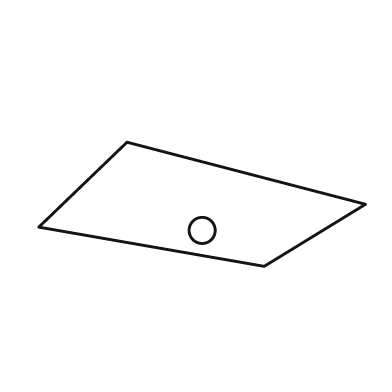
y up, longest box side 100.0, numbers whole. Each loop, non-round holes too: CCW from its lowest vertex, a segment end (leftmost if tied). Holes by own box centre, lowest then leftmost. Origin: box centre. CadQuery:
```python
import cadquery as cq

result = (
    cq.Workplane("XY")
    .moveTo(19.0, -19.0)
    .lineTo(50.0, 0.0)
    .lineTo(-23.0, 19.0)
    .lineTo(-50.0, -7.0)
    .close()
    .moveTo(0.0, -8.0)
    .circle(4.0)
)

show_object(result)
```